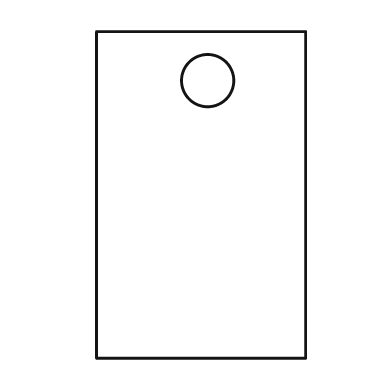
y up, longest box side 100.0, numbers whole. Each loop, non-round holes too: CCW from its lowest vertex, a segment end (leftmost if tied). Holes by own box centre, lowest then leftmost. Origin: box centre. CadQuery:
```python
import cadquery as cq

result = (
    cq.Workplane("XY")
    .moveTo(-32.0, -50.0)
    .lineTo(32.0, -50.0)
    .lineTo(32.0, 50.0)
    .lineTo(-32.0, 50.0)
    .close()
    .moveTo(2.0, 35.0)
    .circle(8.0)
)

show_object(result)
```